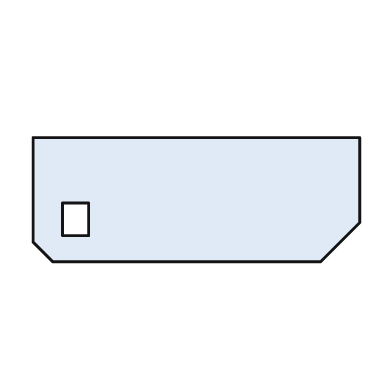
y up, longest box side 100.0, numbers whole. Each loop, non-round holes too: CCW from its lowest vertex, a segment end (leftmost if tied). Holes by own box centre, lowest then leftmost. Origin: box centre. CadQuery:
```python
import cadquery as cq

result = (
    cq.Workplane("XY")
    .moveTo(-44.0, -19.0)
    .lineTo(38.0, -19.0)
    .lineTo(50.0, -7.0)
    .lineTo(50.0, 19.0)
    .lineTo(-50.0, 19.0)
    .lineTo(-50.0, -13.0)
    .close()
    .moveTo(-41.0, -11.0)
    .lineTo(-33.0, -11.0)
    .lineTo(-33.0, -1.0)
    .lineTo(-41.0, -1.0)
    .close()
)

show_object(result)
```